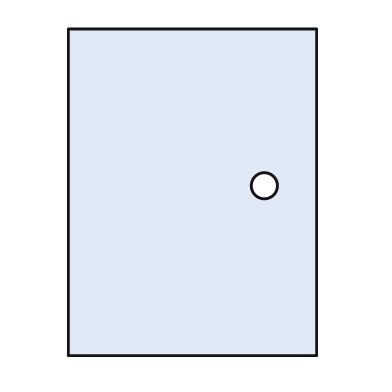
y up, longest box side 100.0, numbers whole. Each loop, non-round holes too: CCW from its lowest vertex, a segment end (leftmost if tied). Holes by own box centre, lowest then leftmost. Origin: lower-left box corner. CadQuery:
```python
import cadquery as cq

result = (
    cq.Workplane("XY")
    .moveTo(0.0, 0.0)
    .lineTo(76.0, 0.0)
    .lineTo(76.0, 100.0)
    .lineTo(0.0, 100.0)
    .close()
    .moveTo(60.0, 52.0)
    .circle(4.0)
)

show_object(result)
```